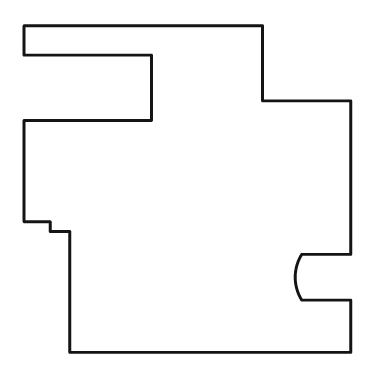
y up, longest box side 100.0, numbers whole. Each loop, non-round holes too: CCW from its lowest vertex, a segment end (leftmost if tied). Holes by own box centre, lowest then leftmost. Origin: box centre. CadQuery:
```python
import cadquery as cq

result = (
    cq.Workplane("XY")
    .moveTo(-36.0, -50.0)
    .lineTo(50.0, -50.0)
    .lineTo(50.0, -34.0)
    .lineTo(35.0, -34.0)
    .threePointArc((33.0, -27.0), (35.0, -20.0))
    .lineTo(50.0, -20.0)
    .lineTo(50.0, 27.0)
    .lineTo(23.0, 27.0)
    .lineTo(23.0, 50.0)
    .lineTo(-50.0, 50.0)
    .lineTo(-50.0, 41.0)
    .lineTo(-11.0, 41.0)
    .lineTo(-11.0, 21.0)
    .lineTo(-50.0, 21.0)
    .lineTo(-50.0, -10.0)
    .lineTo(-42.0, -10.0)
    .lineTo(-42.0, -13.0)
    .lineTo(-36.0, -13.0)
    .close()
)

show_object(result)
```